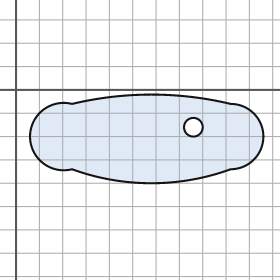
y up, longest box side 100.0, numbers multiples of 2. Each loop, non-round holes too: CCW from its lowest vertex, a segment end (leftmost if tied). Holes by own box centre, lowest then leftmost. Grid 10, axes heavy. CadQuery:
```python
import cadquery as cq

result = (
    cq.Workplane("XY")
    .moveTo(24.0, -34.0)
    .threePointArc((58.0, -40.0), (92.0, -34.0))
    .threePointArc((106.0, -20.0), (92.0, -6.0))
    .threePointArc((58.0, -2.0), (24.0, -6.0))
    .threePointArc((6.0, -20.0), (24.0, -34.0))
    .close()
    .moveTo(76.0, -16.0)
    .circle(4.0)
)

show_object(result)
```